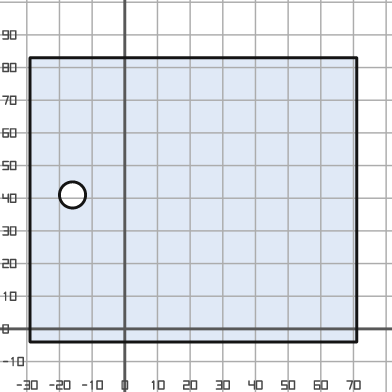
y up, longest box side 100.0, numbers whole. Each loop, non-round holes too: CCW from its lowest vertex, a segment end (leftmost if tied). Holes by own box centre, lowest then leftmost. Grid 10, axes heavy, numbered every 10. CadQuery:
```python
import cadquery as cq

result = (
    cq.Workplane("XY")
    .moveTo(-29.0, -4.0)
    .lineTo(71.0, -4.0)
    .lineTo(71.0, 83.0)
    .lineTo(-29.0, 83.0)
    .close()
    .moveTo(-16.0, 41.0)
    .circle(4.0)
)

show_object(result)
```